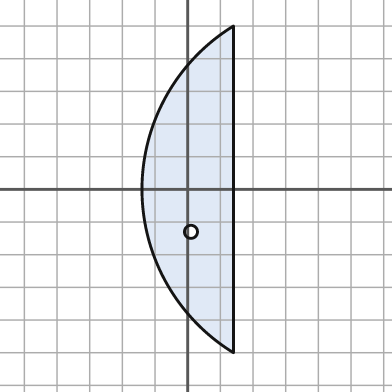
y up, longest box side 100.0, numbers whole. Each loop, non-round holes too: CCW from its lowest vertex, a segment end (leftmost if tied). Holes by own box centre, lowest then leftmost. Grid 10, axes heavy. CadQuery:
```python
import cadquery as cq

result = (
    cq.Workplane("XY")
    .moveTo(14.0, -50.0)
    .lineTo(14.0, 50.0)
    .threePointArc((-14.0, 0.0), (14.0, -50.0))
    .close()
    .moveTo(1.0, -13.0)
    .circle(2.0)
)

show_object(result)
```